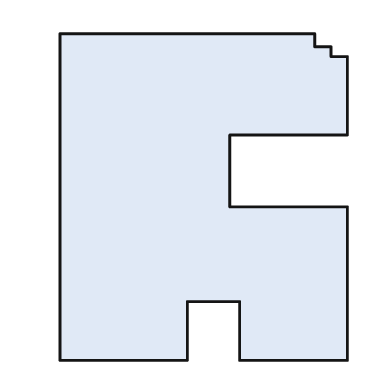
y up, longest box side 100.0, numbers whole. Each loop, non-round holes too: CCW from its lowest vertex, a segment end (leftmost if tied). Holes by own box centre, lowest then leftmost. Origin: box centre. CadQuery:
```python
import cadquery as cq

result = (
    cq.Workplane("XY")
    .moveTo(-44.0, -50.0)
    .lineTo(-5.0, -50.0)
    .lineTo(-5.0, -32.0)
    .lineTo(11.0, -32.0)
    .lineTo(11.0, -50.0)
    .lineTo(44.0, -50.0)
    .lineTo(44.0, -3.0)
    .lineTo(8.0, -3.0)
    .lineTo(8.0, 19.0)
    .lineTo(44.0, 19.0)
    .lineTo(44.0, 43.0)
    .lineTo(39.0, 43.0)
    .lineTo(39.0, 46.0)
    .lineTo(34.0, 46.0)
    .lineTo(34.0, 50.0)
    .lineTo(-44.0, 50.0)
    .close()
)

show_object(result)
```